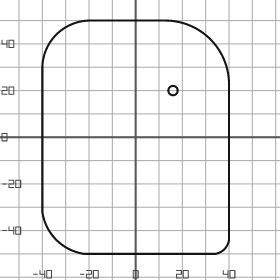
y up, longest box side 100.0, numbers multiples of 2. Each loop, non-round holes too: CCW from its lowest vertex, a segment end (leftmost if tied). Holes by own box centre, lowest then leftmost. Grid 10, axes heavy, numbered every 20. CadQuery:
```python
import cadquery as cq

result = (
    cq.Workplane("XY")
    .moveTo(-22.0, -50.0)
    .lineTo(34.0, -50.0)
    .threePointArc((38.0, -48.0), (40.0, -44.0))
    .lineTo(40.0, 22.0)
    .threePointArc((32.0, 42.0), (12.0, 50.0))
    .lineTo(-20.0, 50.0)
    .threePointArc((-34.0, 44.0), (-40.0, 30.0))
    .lineTo(-40.0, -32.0)
    .threePointArc((-34.0, -44.0), (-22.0, -50.0))
    .close()
    .moveTo(16.0, 20.0)
    .circle(2.0)
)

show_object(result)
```